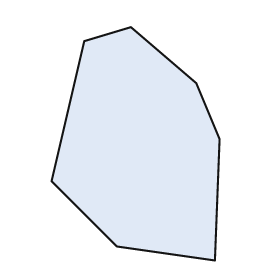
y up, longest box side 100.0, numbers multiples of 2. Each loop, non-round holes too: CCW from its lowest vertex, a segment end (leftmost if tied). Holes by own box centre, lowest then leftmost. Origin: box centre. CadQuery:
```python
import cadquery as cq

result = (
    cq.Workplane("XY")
    .moveTo(34.0, -50.0)
    .lineTo(36.0, 2.0)
    .lineTo(26.0, 26.0)
    .lineTo(-2.0, 50.0)
    .lineTo(-22.0, 44.0)
    .lineTo(-36.0, -16.0)
    .lineTo(-8.0, -44.0)
    .close()
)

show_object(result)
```